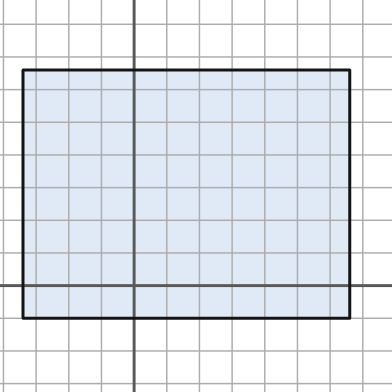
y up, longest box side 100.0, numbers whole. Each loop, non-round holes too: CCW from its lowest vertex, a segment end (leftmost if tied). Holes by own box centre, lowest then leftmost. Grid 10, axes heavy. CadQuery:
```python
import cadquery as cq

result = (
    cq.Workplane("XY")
    .moveTo(-34.0, -10.0)
    .lineTo(66.0, -10.0)
    .lineTo(66.0, 66.0)
    .lineTo(-34.0, 66.0)
    .close()
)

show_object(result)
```